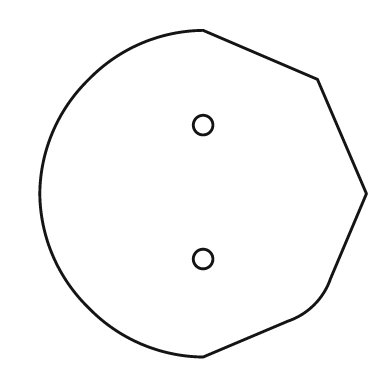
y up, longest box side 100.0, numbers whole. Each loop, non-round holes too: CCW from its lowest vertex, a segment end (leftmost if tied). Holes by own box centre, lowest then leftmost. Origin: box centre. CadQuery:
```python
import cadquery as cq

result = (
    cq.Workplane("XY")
    .moveTo(0.0, -50.0)
    .lineTo(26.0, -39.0)
    .threePointArc((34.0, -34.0), (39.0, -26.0))
    .lineTo(50.0, 0.0)
    .lineTo(35.0, 35.0)
    .lineTo(0.0, 50.0)
    .threePointArc((-19.0, 46.0), (-35.0, 35.0))
    .threePointArc((-46.0, 19.0), (-50.0, 0.0))
    .threePointArc((-46.0, -19.0), (-35.0, -35.0))
    .threePointArc((-19.0, -46.0), (0.0, -50.0))
    .close()
    .moveTo(0.0, -20.0)
    .circle(3.0)
    .moveTo(0.0, 21.0)
    .circle(3.0)
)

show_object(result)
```